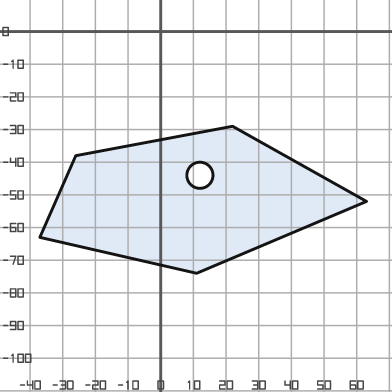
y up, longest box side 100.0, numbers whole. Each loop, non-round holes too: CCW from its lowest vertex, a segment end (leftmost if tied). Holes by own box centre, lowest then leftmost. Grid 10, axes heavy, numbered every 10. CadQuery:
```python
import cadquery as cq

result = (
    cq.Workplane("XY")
    .moveTo(11.0, -74.0)
    .lineTo(63.0, -52.0)
    .lineTo(22.0, -29.0)
    .lineTo(-26.0, -38.0)
    .lineTo(-37.0, -63.0)
    .close()
    .moveTo(12.0, -44.0)
    .circle(4.0)
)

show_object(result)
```